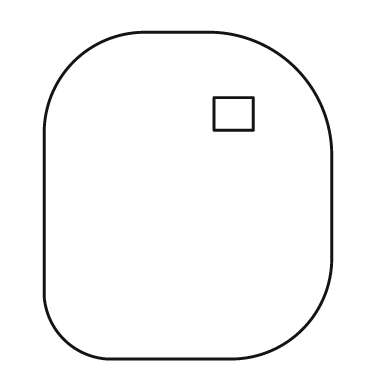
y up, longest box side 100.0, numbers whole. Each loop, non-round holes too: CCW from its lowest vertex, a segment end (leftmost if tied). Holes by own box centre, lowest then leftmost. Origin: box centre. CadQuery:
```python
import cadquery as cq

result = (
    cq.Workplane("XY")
    .moveTo(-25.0, -50.0)
    .lineTo(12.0, -50.0)
    .threePointArc((35.0, -41.0), (44.0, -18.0))
    .lineTo(44.0, 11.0)
    .threePointArc((33.0, 39.0), (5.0, 50.0))
    .lineTo(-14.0, 50.0)
    .threePointArc((-35.0, 41.0), (-44.0, 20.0))
    .lineTo(-44.0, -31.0)
    .threePointArc((-38.0, -44.0), (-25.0, -50.0))
    .close()
    .moveTo(8.0, 20.0)
    .lineTo(20.0, 20.0)
    .lineTo(20.0, 30.0)
    .lineTo(8.0, 30.0)
    .close()
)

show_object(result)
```